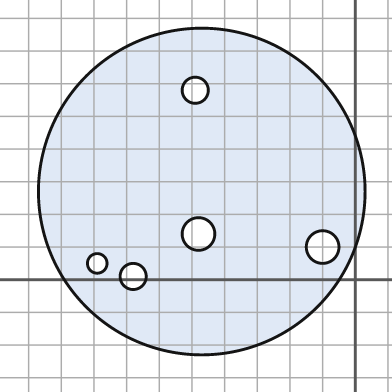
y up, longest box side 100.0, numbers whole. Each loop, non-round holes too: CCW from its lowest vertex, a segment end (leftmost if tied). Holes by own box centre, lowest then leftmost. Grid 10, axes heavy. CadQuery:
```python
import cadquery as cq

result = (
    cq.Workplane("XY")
    .moveTo(-47.0, 27.0)
    .circle(50.0)
    .moveTo(-68.0, 1.0)
    .circle(4.0)
    .moveTo(-79.0, 5.0)
    .circle(3.0)
    .moveTo(-10.0, 10.0)
    .circle(5.0)
    .moveTo(-48.0, 14.0)
    .circle(5.0)
    .moveTo(-49.0, 58.0)
    .circle(4.0)
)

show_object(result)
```